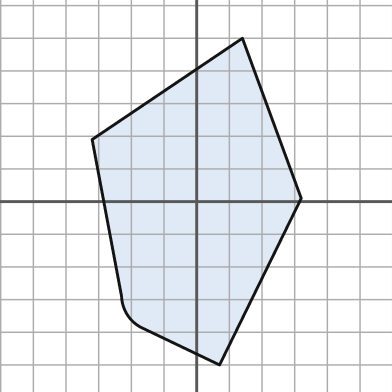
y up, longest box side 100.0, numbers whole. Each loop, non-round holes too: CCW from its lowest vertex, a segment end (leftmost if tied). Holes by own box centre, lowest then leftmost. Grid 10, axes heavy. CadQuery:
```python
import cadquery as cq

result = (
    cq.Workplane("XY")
    .moveTo(7.0, -50.0)
    .lineTo(32.0, 1.0)
    .lineTo(14.0, 50.0)
    .lineTo(-32.0, 19.0)
    .lineTo(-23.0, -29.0)
    .threePointArc((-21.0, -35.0), (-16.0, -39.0))
    .close()
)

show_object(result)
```